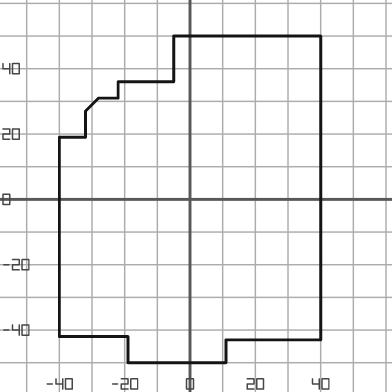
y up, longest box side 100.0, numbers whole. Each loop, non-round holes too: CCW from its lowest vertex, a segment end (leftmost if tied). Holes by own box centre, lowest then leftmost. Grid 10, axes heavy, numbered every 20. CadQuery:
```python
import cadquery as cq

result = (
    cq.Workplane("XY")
    .moveTo(-19.0, -50.0)
    .lineTo(11.0, -50.0)
    .lineTo(11.0, -43.0)
    .lineTo(40.0, -43.0)
    .lineTo(40.0, 50.0)
    .lineTo(-5.0, 50.0)
    .lineTo(-5.0, 36.0)
    .lineTo(-22.0, 36.0)
    .lineTo(-22.0, 31.0)
    .lineTo(-28.0, 31.0)
    .lineTo(-32.0, 27.0)
    .lineTo(-32.0, 19.0)
    .lineTo(-40.0, 19.0)
    .lineTo(-40.0, -42.0)
    .lineTo(-19.0, -42.0)
    .close()
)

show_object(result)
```